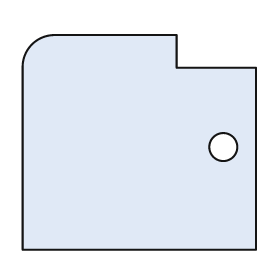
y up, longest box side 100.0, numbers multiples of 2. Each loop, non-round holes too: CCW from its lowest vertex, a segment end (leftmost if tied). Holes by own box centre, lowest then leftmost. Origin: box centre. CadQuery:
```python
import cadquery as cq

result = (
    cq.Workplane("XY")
    .moveTo(-50.0, -46.0)
    .lineTo(50.0, -46.0)
    .lineTo(50.0, 32.0)
    .lineTo(16.0, 32.0)
    .lineTo(16.0, 46.0)
    .lineTo(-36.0, 46.0)
    .threePointArc((-46.0, 42.0), (-50.0, 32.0))
    .close()
    .moveTo(36.0, -2.0)
    .circle(6.0)
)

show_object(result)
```